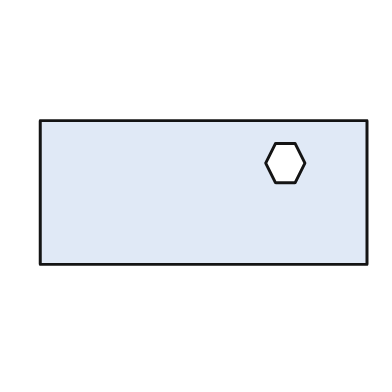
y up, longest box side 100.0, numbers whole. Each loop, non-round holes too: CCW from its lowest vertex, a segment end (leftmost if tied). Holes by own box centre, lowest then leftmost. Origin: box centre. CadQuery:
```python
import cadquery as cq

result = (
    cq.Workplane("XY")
    .moveTo(-50.0, -22.0)
    .lineTo(50.0, -22.0)
    .lineTo(50.0, 22.0)
    .lineTo(-50.0, 22.0)
    .close()
    .moveTo(22.0, 3.0)
    .lineTo(28.0, 3.0)
    .lineTo(31.0, 9.0)
    .lineTo(28.0, 15.0)
    .lineTo(22.0, 15.0)
    .lineTo(19.0, 9.0)
    .close()
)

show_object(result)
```